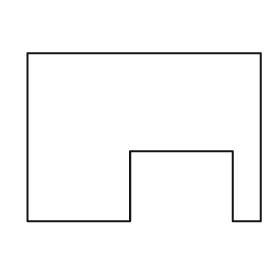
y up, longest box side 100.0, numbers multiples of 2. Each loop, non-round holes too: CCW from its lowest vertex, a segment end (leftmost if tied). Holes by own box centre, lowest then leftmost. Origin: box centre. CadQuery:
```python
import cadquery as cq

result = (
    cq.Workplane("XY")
    .moveTo(-50.0, -36.0)
    .lineTo(-6.0, -36.0)
    .lineTo(-6.0, -6.0)
    .lineTo(38.0, -6.0)
    .lineTo(38.0, -36.0)
    .lineTo(50.0, -36.0)
    .lineTo(50.0, 36.0)
    .lineTo(-50.0, 36.0)
    .close()
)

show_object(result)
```